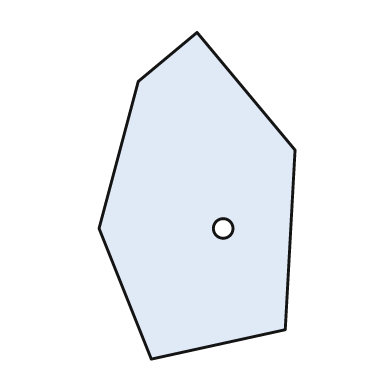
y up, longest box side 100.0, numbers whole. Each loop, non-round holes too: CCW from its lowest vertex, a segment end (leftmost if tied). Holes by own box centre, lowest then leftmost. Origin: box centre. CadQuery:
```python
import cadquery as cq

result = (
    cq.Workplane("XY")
    .moveTo(-14.0, -50.0)
    .lineTo(27.0, -41.0)
    .lineTo(30.0, 14.0)
    .lineTo(0.0, 50.0)
    .lineTo(-18.0, 35.0)
    .lineTo(-30.0, -10.0)
    .close()
    .moveTo(8.0, -10.0)
    .circle(3.0)
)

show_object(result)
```